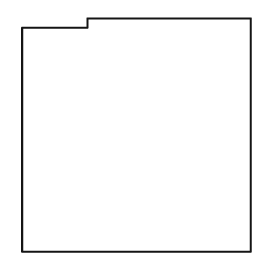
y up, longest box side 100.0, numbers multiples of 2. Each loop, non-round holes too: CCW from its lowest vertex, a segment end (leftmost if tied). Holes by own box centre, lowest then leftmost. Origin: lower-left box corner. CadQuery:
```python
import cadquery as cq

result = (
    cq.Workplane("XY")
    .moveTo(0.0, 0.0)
    .lineTo(98.0, 0.0)
    .lineTo(98.0, 100.0)
    .lineTo(28.0, 100.0)
    .lineTo(28.0, 96.0)
    .lineTo(0.0, 96.0)
    .close()
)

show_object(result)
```